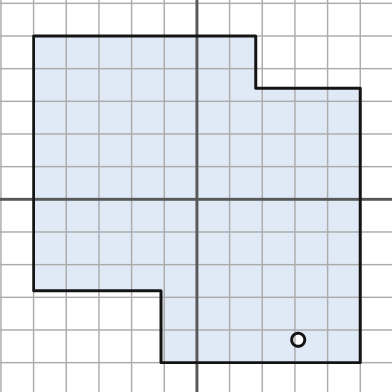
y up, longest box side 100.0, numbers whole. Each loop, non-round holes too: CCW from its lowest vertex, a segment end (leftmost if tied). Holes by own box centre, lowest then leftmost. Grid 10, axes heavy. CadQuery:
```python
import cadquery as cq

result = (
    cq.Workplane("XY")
    .moveTo(-11.0, -50.0)
    .lineTo(50.0, -50.0)
    .lineTo(50.0, 34.0)
    .lineTo(18.0, 34.0)
    .lineTo(18.0, 50.0)
    .lineTo(-50.0, 50.0)
    .lineTo(-50.0, -28.0)
    .lineTo(-11.0, -28.0)
    .close()
    .moveTo(31.0, -43.0)
    .circle(2.0)
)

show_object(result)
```